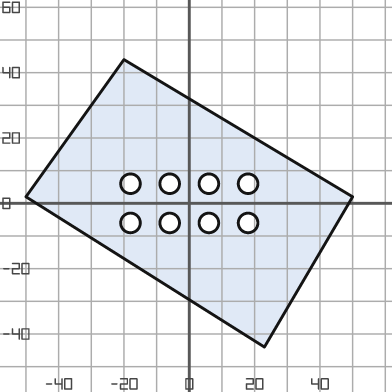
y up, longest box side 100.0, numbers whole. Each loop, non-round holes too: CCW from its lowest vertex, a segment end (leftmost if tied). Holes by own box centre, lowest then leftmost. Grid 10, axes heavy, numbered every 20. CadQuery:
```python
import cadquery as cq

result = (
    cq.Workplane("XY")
    .moveTo(23.0, -44.0)
    .lineTo(50.0, 2.0)
    .lineTo(-20.0, 44.0)
    .lineTo(-50.0, 2.0)
    .close()
    .moveTo(-18.0, -6.0)
    .circle(3.0)
    .moveTo(-6.0, -6.0)
    .circle(3.0)
    .moveTo(6.0, -6.0)
    .circle(3.0)
    .moveTo(18.0, -6.0)
    .circle(3.0)
    .moveTo(-18.0, 6.0)
    .circle(3.0)
    .moveTo(-6.0, 6.0)
    .circle(3.0)
    .moveTo(6.0, 6.0)
    .circle(3.0)
    .moveTo(18.0, 6.0)
    .circle(3.0)
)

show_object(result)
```